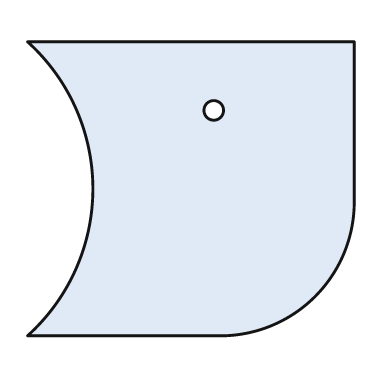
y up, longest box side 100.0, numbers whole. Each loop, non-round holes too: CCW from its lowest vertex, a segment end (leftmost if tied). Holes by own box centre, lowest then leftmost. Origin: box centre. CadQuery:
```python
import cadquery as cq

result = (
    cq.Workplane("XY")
    .moveTo(-50.0, -45.0)
    .lineTo(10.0, -45.0)
    .threePointArc((38.0, -33.0), (50.0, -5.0))
    .lineTo(50.0, 45.0)
    .lineTo(-50.0, 45.0)
    .threePointArc((-30.0, 0.0), (-50.0, -45.0))
    .close()
    .moveTo(7.0, 24.0)
    .circle(3.0)
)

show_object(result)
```